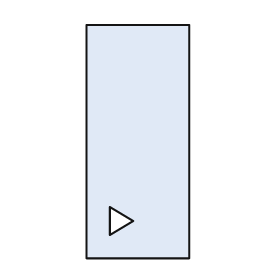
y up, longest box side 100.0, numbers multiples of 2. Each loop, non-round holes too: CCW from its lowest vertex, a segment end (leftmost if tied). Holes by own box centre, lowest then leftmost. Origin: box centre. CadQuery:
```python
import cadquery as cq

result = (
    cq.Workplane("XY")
    .moveTo(-22.0, -50.0)
    .lineTo(22.0, -50.0)
    .lineTo(22.0, 50.0)
    .lineTo(-22.0, 50.0)
    .close()
    .moveTo(-12.0, -40.0)
    .lineTo(-2.0, -34.0)
    .lineTo(-12.0, -28.0)
    .close()
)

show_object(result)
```